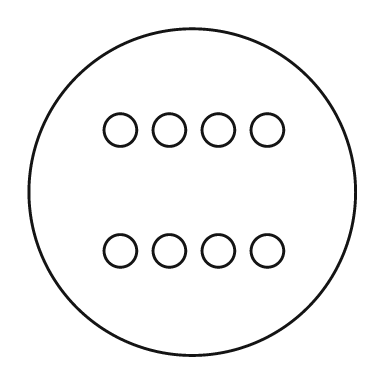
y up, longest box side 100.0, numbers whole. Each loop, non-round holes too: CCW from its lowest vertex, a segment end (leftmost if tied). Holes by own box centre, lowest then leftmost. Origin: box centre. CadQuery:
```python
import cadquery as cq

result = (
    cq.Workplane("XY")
    .moveTo(0.0, 0.0)
    .circle(50.0)
    .moveTo(-22.0, -18.0)
    .circle(5.0)
    .moveTo(-7.0, -18.0)
    .circle(5.0)
    .moveTo(8.0, -18.0)
    .circle(5.0)
    .moveTo(23.0, -18.0)
    .circle(5.0)
    .moveTo(-22.0, 19.0)
    .circle(5.0)
    .moveTo(-7.0, 19.0)
    .circle(5.0)
    .moveTo(8.0, 19.0)
    .circle(5.0)
    .moveTo(23.0, 19.0)
    .circle(5.0)
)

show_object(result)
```